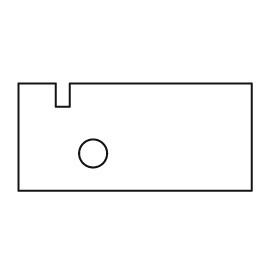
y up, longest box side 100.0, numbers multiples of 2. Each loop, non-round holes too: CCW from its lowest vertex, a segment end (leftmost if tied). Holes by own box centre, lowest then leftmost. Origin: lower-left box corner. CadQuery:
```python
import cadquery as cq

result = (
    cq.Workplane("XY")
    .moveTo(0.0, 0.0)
    .lineTo(100.0, 0.0)
    .lineTo(100.0, 46.0)
    .lineTo(22.0, 46.0)
    .lineTo(22.0, 36.0)
    .lineTo(16.0, 36.0)
    .lineTo(16.0, 46.0)
    .lineTo(0.0, 46.0)
    .close()
    .moveTo(32.0, 16.0)
    .circle(6.0)
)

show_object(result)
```